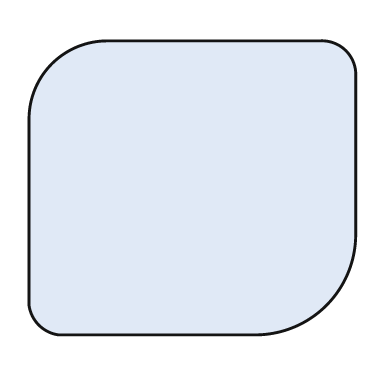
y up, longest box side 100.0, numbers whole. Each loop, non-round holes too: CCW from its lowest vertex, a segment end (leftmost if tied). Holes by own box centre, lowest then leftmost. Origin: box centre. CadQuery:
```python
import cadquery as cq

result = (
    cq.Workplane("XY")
    .moveTo(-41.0, -45.0)
    .lineTo(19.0, -45.0)
    .threePointArc((41.0, -36.0), (50.0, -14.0))
    .lineTo(50.0, 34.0)
    .threePointArc((47.0, 42.0), (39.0, 45.0))
    .lineTo(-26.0, 45.0)
    .threePointArc((-43.0, 38.0), (-50.0, 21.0))
    .lineTo(-50.0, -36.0)
    .threePointArc((-47.0, -42.0), (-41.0, -45.0))
    .close()
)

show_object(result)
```